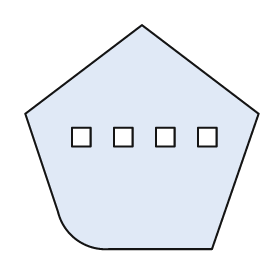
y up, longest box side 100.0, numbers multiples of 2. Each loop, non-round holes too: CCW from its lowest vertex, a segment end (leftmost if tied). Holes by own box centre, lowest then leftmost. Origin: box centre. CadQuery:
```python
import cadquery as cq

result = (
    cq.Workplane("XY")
    .moveTo(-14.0, -48.0)
    .lineTo(30.0, -48.0)
    .lineTo(50.0, 10.0)
    .lineTo(0.0, 48.0)
    .lineTo(-50.0, 10.0)
    .lineTo(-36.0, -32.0)
    .threePointArc((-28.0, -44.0), (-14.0, -48.0))
    .close()
    .moveTo(-30.0, -4.0)
    .lineTo(-22.0, -4.0)
    .lineTo(-22.0, 4.0)
    .lineTo(-30.0, 4.0)
    .close()
    .moveTo(-12.0, -4.0)
    .lineTo(-4.0, -4.0)
    .lineTo(-4.0, 4.0)
    .lineTo(-12.0, 4.0)
    .close()
    .moveTo(6.0, -4.0)
    .lineTo(14.0, -4.0)
    .lineTo(14.0, 4.0)
    .lineTo(6.0, 4.0)
    .close()
    .moveTo(24.0, -4.0)
    .lineTo(32.0, -4.0)
    .lineTo(32.0, 4.0)
    .lineTo(24.0, 4.0)
    .close()
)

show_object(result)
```